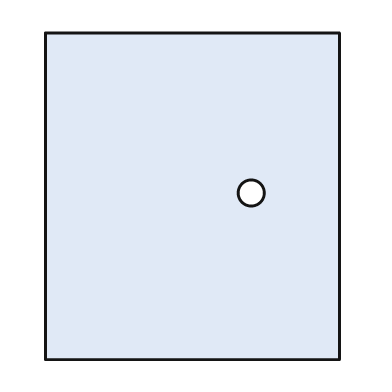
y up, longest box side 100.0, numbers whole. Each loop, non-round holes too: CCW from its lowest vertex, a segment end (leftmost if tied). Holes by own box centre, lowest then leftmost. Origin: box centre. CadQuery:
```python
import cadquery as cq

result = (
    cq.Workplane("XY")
    .moveTo(-45.0, -50.0)
    .lineTo(45.0, -50.0)
    .lineTo(45.0, 50.0)
    .lineTo(-45.0, 50.0)
    .close()
    .moveTo(18.0, 1.0)
    .circle(4.0)
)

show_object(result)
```